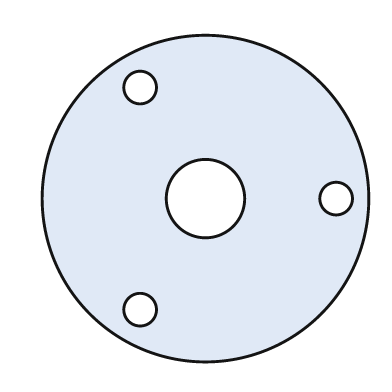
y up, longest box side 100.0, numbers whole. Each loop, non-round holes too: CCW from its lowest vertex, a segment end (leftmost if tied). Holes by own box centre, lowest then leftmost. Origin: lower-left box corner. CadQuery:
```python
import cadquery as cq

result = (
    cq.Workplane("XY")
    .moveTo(50.0, 50.0)
    .circle(50.0)
    .moveTo(30.0, 16.0)
    .circle(5.0)
    .moveTo(50.0, 50.0)
    .circle(12.0)
    .moveTo(90.0, 50.0)
    .circle(5.0)
    .moveTo(30.0, 84.0)
    .circle(5.0)
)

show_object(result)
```